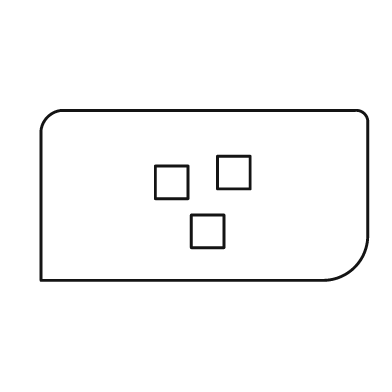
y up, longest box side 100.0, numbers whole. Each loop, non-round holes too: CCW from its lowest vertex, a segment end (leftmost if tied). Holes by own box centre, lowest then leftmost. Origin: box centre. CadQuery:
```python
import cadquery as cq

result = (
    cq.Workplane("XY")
    .moveTo(-50.0, -26.0)
    .lineTo(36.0, -26.0)
    .threePointArc((46.0, -22.0), (50.0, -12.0))
    .lineTo(50.0, 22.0)
    .threePointArc((49.0, 25.0), (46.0, 26.0))
    .lineTo(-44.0, 26.0)
    .threePointArc((-48.0, 24.0), (-50.0, 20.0))
    .close()
    .moveTo(-4.0, -16.0)
    .lineTo(6.0, -16.0)
    .lineTo(6.0, -6.0)
    .lineTo(-4.0, -6.0)
    .close()
    .moveTo(-15.0, -1.0)
    .lineTo(-5.0, -1.0)
    .lineTo(-5.0, 9.0)
    .lineTo(-15.0, 9.0)
    .close()
    .moveTo(4.0, 2.0)
    .lineTo(14.0, 2.0)
    .lineTo(14.0, 12.0)
    .lineTo(4.0, 12.0)
    .close()
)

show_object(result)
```